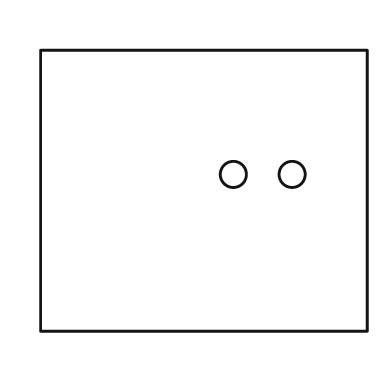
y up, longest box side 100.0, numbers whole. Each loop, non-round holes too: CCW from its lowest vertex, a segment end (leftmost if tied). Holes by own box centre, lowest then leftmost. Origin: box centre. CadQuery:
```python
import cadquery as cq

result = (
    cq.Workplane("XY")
    .moveTo(-50.0, -43.0)
    .lineTo(50.0, -43.0)
    .lineTo(50.0, 43.0)
    .lineTo(-50.0, 43.0)
    .close()
    .moveTo(9.0, 5.0)
    .circle(4.0)
    .moveTo(27.0, 5.0)
    .circle(4.0)
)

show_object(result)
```